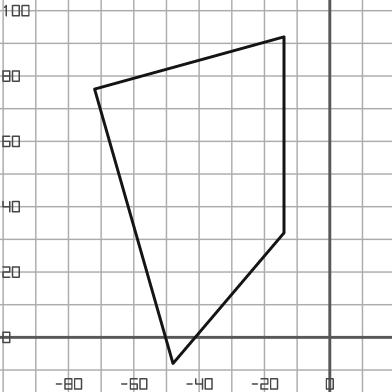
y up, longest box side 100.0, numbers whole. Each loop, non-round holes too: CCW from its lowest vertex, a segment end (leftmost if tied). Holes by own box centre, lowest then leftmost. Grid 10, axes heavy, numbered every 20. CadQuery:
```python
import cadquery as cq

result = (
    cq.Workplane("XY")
    .moveTo(-48.0, -8.0)
    .lineTo(-14.0, 32.0)
    .lineTo(-14.0, 92.0)
    .lineTo(-72.0, 76.0)
    .close()
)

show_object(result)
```